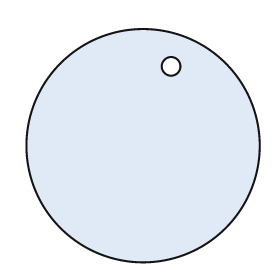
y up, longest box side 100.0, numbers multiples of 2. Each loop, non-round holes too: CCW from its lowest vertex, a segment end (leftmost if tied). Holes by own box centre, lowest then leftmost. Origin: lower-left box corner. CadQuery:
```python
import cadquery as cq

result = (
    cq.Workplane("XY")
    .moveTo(50.0, 50.0)
    .circle(50.0)
    .moveTo(62.0, 84.0)
    .circle(4.0)
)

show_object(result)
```